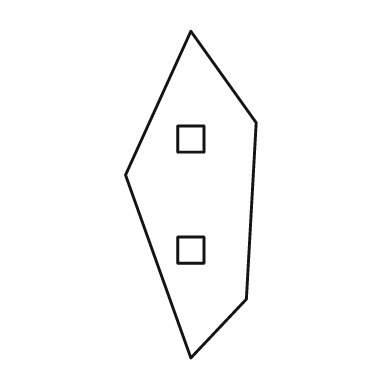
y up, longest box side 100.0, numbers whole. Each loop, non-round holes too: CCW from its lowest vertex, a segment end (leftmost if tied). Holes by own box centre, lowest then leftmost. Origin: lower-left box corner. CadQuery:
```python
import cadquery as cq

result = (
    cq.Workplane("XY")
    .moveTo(20.0, 0.0)
    .lineTo(37.0, 18.0)
    .lineTo(40.0, 72.0)
    .lineTo(20.0, 100.0)
    .lineTo(0.0, 56.0)
    .close()
    .moveTo(16.0, 29.0)
    .lineTo(24.0, 29.0)
    .lineTo(24.0, 37.0)
    .lineTo(16.0, 37.0)
    .close()
    .moveTo(16.0, 63.0)
    .lineTo(24.0, 63.0)
    .lineTo(24.0, 71.0)
    .lineTo(16.0, 71.0)
    .close()
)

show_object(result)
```